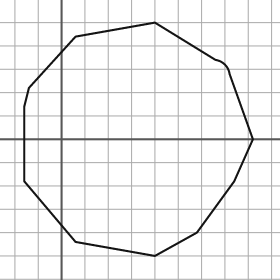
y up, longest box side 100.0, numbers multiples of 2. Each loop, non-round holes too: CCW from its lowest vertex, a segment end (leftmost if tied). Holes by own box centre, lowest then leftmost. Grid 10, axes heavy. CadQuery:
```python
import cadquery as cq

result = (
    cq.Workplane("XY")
    .moveTo(40.0, -50.0)
    .lineTo(58.0, -40.0)
    .lineTo(74.0, -18.0)
    .lineTo(82.0, 0.0)
    .lineTo(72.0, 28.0)
    .threePointArc((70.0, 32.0), (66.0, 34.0))
    .lineTo(40.0, 50.0)
    .lineTo(6.0, 44.0)
    .lineTo(-14.0, 22.0)
    .lineTo(-16.0, 14.0)
    .lineTo(-16.0, -18.0)
    .lineTo(6.0, -44.0)
    .close()
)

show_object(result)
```